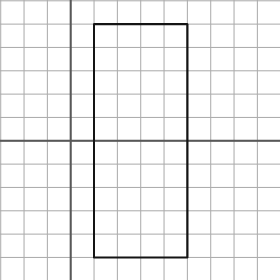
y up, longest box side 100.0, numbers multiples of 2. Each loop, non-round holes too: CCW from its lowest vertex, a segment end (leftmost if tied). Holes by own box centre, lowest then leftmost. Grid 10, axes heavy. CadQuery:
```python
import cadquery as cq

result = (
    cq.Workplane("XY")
    .moveTo(10.0, -50.0)
    .lineTo(50.0, -50.0)
    .lineTo(50.0, 50.0)
    .lineTo(10.0, 50.0)
    .close()
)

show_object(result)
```